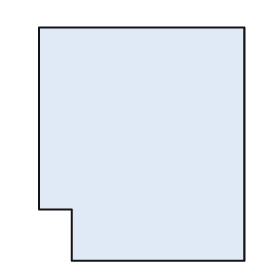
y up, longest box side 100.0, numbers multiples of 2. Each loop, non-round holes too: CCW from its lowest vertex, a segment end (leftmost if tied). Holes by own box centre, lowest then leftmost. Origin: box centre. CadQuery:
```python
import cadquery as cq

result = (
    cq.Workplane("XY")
    .moveTo(-30.0, -50.0)
    .lineTo(44.0, -50.0)
    .lineTo(44.0, 50.0)
    .lineTo(-44.0, 50.0)
    .lineTo(-44.0, -28.0)
    .lineTo(-30.0, -28.0)
    .close()
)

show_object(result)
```